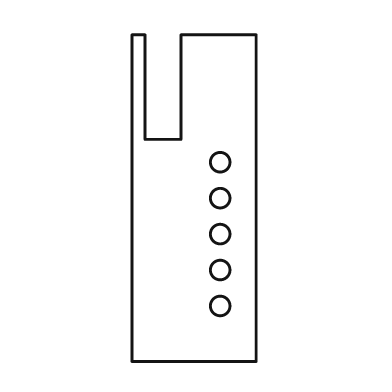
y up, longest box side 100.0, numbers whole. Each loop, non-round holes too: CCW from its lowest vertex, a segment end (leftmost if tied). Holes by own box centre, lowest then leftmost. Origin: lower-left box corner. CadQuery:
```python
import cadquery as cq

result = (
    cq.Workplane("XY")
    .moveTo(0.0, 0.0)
    .lineTo(38.0, 0.0)
    .lineTo(38.0, 100.0)
    .lineTo(15.0, 100.0)
    .lineTo(15.0, 68.0)
    .lineTo(4.0, 68.0)
    .lineTo(4.0, 100.0)
    .lineTo(0.0, 100.0)
    .close()
    .moveTo(27.0, 17.0)
    .circle(3.0)
    .moveTo(27.0, 28.0)
    .circle(3.0)
    .moveTo(27.0, 39.0)
    .circle(3.0)
    .moveTo(27.0, 50.0)
    .circle(3.0)
    .moveTo(27.0, 61.0)
    .circle(3.0)
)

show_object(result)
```